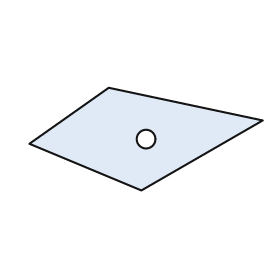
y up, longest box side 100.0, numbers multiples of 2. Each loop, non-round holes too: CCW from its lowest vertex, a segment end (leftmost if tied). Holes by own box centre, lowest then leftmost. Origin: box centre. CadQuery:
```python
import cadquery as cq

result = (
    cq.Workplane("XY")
    .moveTo(-2.0, -22.0)
    .lineTo(50.0, 8.0)
    .lineTo(-16.0, 22.0)
    .lineTo(-50.0, -2.0)
    .close()
    .moveTo(0.0, 0.0)
    .circle(4.0)
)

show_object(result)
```